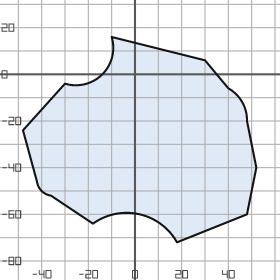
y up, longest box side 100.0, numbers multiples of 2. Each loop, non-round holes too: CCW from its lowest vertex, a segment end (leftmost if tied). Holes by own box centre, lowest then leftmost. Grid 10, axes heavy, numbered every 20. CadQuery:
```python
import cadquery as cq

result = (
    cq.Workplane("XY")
    .moveTo(18.0, -72.0)
    .lineTo(48.0, -60.0)
    .lineTo(52.0, -40.0)
    .lineTo(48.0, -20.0)
    .threePointArc((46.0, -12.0), (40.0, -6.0))
    .lineTo(30.0, 6.0)
    .lineTo(-10.0, 16.0)
    .threePointArc((-14.0, 0.0), (-30.0, -4.0))
    .lineTo(-48.0, -24.0)
    .lineTo(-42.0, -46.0)
    .threePointArc((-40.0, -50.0), (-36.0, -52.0))
    .lineTo(-18.0, -64.0)
    .threePointArc((2.0, -60.0), (18.0, -72.0))
    .close()
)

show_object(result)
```